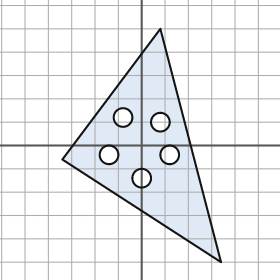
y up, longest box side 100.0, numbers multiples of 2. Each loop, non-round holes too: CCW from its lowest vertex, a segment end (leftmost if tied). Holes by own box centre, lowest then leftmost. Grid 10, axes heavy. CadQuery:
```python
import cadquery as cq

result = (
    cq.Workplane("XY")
    .moveTo(34.0, -50.0)
    .lineTo(8.0, 50.0)
    .lineTo(-34.0, -6.0)
    .close()
    .moveTo(0.0, -14.0)
    .circle(4.0)
    .moveTo(-14.0, -4.0)
    .circle(4.0)
    .moveTo(12.0, -4.0)
    .circle(4.0)
    .moveTo(8.0, 10.0)
    .circle(4.0)
    .moveTo(-8.0, 12.0)
    .circle(4.0)
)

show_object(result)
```